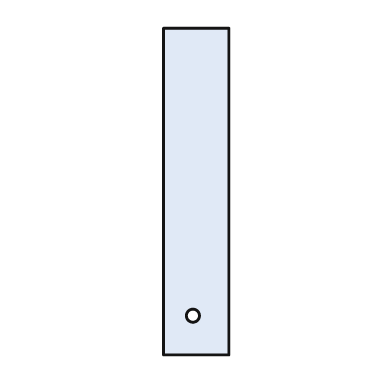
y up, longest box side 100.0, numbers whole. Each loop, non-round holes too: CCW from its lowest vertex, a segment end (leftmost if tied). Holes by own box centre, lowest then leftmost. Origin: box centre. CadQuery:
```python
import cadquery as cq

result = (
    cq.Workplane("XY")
    .moveTo(-10.0, -50.0)
    .lineTo(10.0, -50.0)
    .lineTo(10.0, 50.0)
    .lineTo(-10.0, 50.0)
    .close()
    .moveTo(-1.0, -38.0)
    .circle(2.0)
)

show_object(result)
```